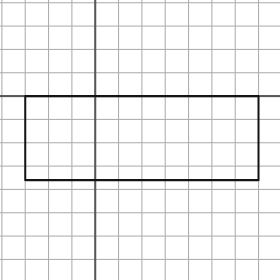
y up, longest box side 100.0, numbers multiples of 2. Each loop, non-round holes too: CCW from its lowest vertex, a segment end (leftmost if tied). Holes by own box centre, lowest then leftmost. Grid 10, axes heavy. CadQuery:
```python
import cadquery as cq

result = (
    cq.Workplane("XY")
    .moveTo(-30.0, -36.0)
    .lineTo(70.0, -36.0)
    .lineTo(70.0, 0.0)
    .lineTo(-30.0, 0.0)
    .close()
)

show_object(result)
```